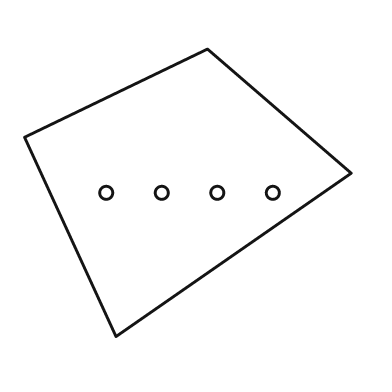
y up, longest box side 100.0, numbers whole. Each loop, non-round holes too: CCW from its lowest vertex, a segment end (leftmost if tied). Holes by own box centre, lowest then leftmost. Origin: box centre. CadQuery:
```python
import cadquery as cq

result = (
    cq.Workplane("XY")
    .moveTo(-22.0, -44.0)
    .lineTo(50.0, 6.0)
    .lineTo(6.0, 44.0)
    .lineTo(-50.0, 17.0)
    .close()
    .moveTo(-25.0, 0.0)
    .circle(2.0)
    .moveTo(-8.0, 0.0)
    .circle(2.0)
    .moveTo(9.0, 0.0)
    .circle(2.0)
    .moveTo(26.0, 0.0)
    .circle(2.0)
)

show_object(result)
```